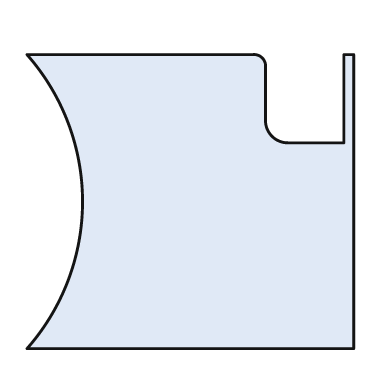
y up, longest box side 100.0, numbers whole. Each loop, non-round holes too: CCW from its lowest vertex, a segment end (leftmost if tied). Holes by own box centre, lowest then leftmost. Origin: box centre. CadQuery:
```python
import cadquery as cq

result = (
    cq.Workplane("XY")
    .moveTo(-50.0, -45.0)
    .lineTo(50.0, -45.0)
    .lineTo(50.0, 45.0)
    .lineTo(47.0, 45.0)
    .lineTo(47.0, 18.0)
    .lineTo(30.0, 18.0)
    .threePointArc((25.0, 20.0), (23.0, 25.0))
    .lineTo(23.0, 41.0)
    .threePointArc((22.0, 44.0), (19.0, 45.0))
    .lineTo(-50.0, 45.0)
    .threePointArc((-33.0, 0.0), (-50.0, -45.0))
    .close()
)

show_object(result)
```